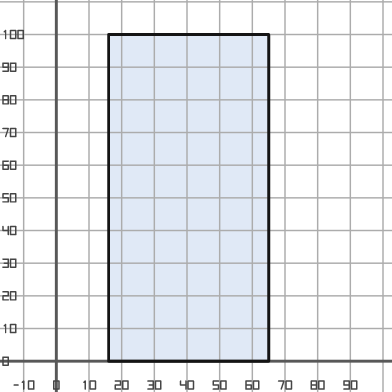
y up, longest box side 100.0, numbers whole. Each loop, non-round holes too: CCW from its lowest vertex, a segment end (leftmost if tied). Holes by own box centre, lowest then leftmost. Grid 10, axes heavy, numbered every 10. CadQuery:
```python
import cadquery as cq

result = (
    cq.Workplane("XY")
    .moveTo(16.0, 0.0)
    .lineTo(65.0, 0.0)
    .lineTo(65.0, 100.0)
    .lineTo(16.0, 100.0)
    .close()
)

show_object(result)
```